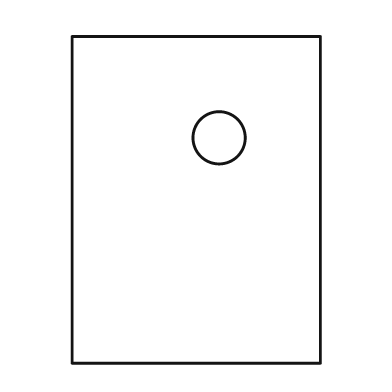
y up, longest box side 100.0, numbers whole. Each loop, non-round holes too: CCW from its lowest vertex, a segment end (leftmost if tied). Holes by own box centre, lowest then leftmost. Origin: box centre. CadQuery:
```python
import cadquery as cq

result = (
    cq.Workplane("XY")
    .moveTo(-38.0, -50.0)
    .lineTo(38.0, -50.0)
    .lineTo(38.0, 50.0)
    .lineTo(-38.0, 50.0)
    .close()
    .moveTo(7.0, 19.0)
    .circle(8.0)
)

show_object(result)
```